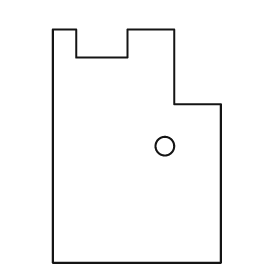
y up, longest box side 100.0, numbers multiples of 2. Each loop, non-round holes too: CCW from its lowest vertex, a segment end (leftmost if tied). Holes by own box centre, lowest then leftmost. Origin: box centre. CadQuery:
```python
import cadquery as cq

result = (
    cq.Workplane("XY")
    .moveTo(-36.0, -50.0)
    .lineTo(36.0, -50.0)
    .lineTo(36.0, 18.0)
    .lineTo(16.0, 18.0)
    .lineTo(16.0, 50.0)
    .lineTo(-4.0, 50.0)
    .lineTo(-4.0, 38.0)
    .lineTo(-26.0, 38.0)
    .lineTo(-26.0, 50.0)
    .lineTo(-36.0, 50.0)
    .close()
    .moveTo(12.0, 0.0)
    .circle(4.0)
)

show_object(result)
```